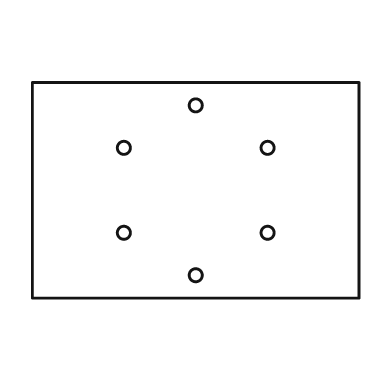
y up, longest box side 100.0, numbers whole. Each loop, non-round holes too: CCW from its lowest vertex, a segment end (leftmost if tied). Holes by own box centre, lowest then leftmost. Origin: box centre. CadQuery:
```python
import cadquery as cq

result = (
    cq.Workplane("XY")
    .moveTo(-50.0, -33.0)
    .lineTo(50.0, -33.0)
    .lineTo(50.0, 33.0)
    .lineTo(-50.0, 33.0)
    .close()
    .moveTo(0.0, -26.0)
    .circle(2.0)
    .moveTo(-22.0, -13.0)
    .circle(2.0)
    .moveTo(22.0, -13.0)
    .circle(2.0)
    .moveTo(-22.0, 13.0)
    .circle(2.0)
    .moveTo(22.0, 13.0)
    .circle(2.0)
    .moveTo(0.0, 26.0)
    .circle(2.0)
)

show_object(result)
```